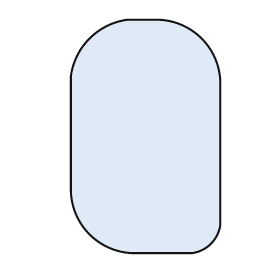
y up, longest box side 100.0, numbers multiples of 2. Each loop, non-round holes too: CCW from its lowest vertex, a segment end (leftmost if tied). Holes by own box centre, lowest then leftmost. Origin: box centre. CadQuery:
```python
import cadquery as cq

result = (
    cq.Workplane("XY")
    .moveTo(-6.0, -50.0)
    .lineTo(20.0, -50.0)
    .threePointArc((28.0, -46.0), (32.0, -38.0))
    .lineTo(32.0, 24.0)
    .threePointArc((24.0, 42.0), (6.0, 50.0))
    .lineTo(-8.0, 50.0)
    .threePointArc((-24.0, 42.0), (-32.0, 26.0))
    .lineTo(-32.0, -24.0)
    .threePointArc((-24.0, -42.0), (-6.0, -50.0))
    .close()
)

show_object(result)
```